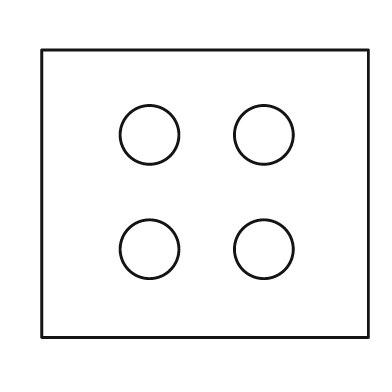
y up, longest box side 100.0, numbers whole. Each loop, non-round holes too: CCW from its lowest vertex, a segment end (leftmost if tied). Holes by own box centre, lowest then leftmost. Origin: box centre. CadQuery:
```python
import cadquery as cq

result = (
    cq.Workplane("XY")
    .moveTo(-50.0, -44.0)
    .lineTo(50.0, -44.0)
    .lineTo(50.0, 44.0)
    .lineTo(-50.0, 44.0)
    .close()
    .moveTo(-17.0, -17.0)
    .circle(9.0)
    .moveTo(18.0, -17.0)
    .circle(9.0)
    .moveTo(-17.0, 18.0)
    .circle(9.0)
    .moveTo(18.0, 18.0)
    .circle(9.0)
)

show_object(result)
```